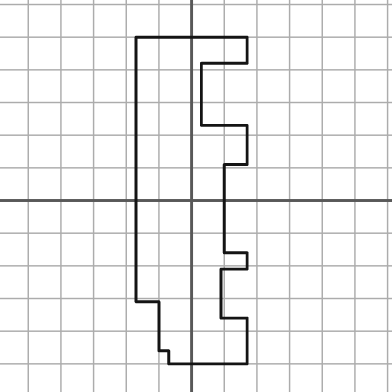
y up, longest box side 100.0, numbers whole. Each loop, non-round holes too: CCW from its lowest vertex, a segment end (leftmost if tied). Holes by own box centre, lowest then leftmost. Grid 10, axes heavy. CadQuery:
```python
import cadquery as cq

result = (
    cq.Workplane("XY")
    .moveTo(-7.0, -50.0)
    .lineTo(17.0, -50.0)
    .lineTo(17.0, -36.0)
    .lineTo(9.0, -36.0)
    .lineTo(9.0, -21.0)
    .lineTo(17.0, -21.0)
    .lineTo(17.0, -16.0)
    .lineTo(10.0, -16.0)
    .lineTo(10.0, 11.0)
    .lineTo(17.0, 11.0)
    .lineTo(17.0, 23.0)
    .lineTo(3.0, 23.0)
    .lineTo(3.0, 42.0)
    .lineTo(17.0, 42.0)
    .lineTo(17.0, 50.0)
    .lineTo(-17.0, 50.0)
    .lineTo(-17.0, -31.0)
    .lineTo(-10.0, -31.0)
    .lineTo(-10.0, -46.0)
    .lineTo(-7.0, -46.0)
    .close()
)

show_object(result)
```